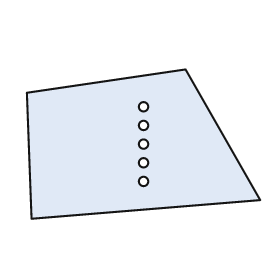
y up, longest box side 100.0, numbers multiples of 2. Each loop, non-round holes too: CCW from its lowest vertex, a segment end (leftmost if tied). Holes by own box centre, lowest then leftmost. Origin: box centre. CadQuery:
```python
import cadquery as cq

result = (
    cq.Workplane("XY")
    .moveTo(-48.0, -32.0)
    .lineTo(50.0, -24.0)
    .lineTo(18.0, 32.0)
    .lineTo(-50.0, 22.0)
    .close()
    .moveTo(0.0, -16.0)
    .circle(2.0)
    .moveTo(0.0, -8.0)
    .circle(2.0)
    .moveTo(0.0, 0.0)
    .circle(2.0)
    .moveTo(0.0, 8.0)
    .circle(2.0)
    .moveTo(0.0, 16.0)
    .circle(2.0)
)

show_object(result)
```